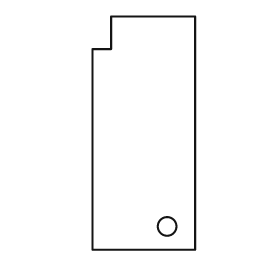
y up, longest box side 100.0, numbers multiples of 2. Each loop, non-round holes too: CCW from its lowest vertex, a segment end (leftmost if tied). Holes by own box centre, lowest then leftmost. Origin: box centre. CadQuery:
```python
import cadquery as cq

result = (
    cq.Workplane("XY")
    .moveTo(-22.0, -50.0)
    .lineTo(22.0, -50.0)
    .lineTo(22.0, 50.0)
    .lineTo(-14.0, 50.0)
    .lineTo(-14.0, 36.0)
    .lineTo(-22.0, 36.0)
    .close()
    .moveTo(10.0, -40.0)
    .circle(4.0)
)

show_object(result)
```